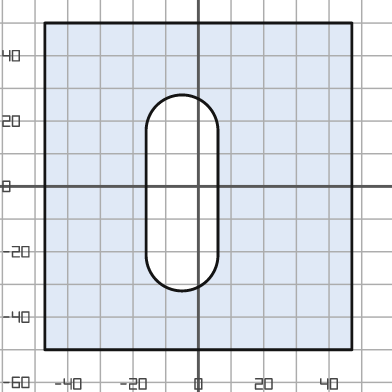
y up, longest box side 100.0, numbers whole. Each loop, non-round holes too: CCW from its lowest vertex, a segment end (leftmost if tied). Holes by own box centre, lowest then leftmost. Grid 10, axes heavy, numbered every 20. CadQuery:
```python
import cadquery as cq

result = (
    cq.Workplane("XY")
    .moveTo(-47.0, -50.0)
    .lineTo(47.0, -50.0)
    .lineTo(47.0, 50.0)
    .lineTo(-47.0, 50.0)
    .close()
    .moveTo(-16.0, -21.0)
    .threePointArc((-5.0, -32.0), (6.0, -21.0))
    .lineTo(6.0, 17.0)
    .threePointArc((-5.0, 28.0), (-16.0, 17.0))
    .close()
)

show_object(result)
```